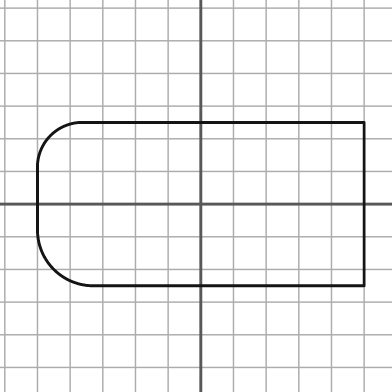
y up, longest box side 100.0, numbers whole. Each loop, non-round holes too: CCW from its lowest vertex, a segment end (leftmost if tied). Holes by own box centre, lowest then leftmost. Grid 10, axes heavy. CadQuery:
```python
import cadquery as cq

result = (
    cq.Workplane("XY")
    .moveTo(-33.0, -25.0)
    .lineTo(50.0, -25.0)
    .lineTo(50.0, 25.0)
    .lineTo(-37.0, 25.0)
    .threePointArc((-46.0, 21.0), (-50.0, 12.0))
    .lineTo(-50.0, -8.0)
    .threePointArc((-45.0, -20.0), (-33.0, -25.0))
    .close()
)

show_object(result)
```